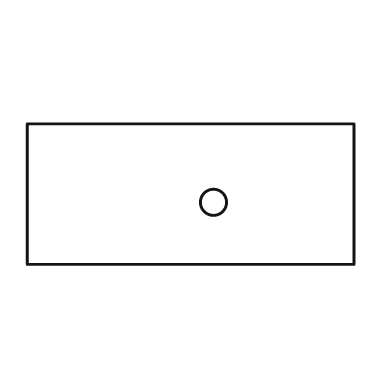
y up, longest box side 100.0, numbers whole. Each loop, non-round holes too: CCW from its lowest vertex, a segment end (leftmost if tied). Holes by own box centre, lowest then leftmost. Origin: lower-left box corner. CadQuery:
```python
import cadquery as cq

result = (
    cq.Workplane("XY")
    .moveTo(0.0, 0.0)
    .lineTo(100.0, 0.0)
    .lineTo(100.0, 43.0)
    .lineTo(0.0, 43.0)
    .close()
    .moveTo(57.0, 19.0)
    .circle(4.0)
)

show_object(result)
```